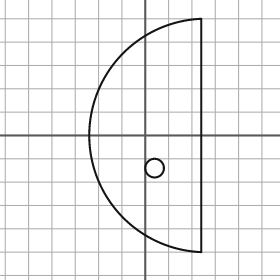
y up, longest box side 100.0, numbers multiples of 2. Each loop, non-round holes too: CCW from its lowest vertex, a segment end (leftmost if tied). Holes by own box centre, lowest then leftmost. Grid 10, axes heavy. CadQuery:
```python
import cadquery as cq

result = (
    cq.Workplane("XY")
    .moveTo(24.0, -50.0)
    .lineTo(24.0, 50.0)
    .threePointArc((-24.0, 0.0), (24.0, -50.0))
    .close()
    .moveTo(4.0, -14.0)
    .circle(4.0)
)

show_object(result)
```